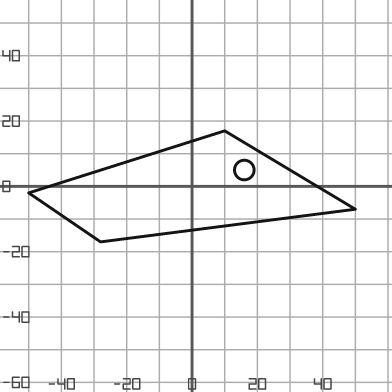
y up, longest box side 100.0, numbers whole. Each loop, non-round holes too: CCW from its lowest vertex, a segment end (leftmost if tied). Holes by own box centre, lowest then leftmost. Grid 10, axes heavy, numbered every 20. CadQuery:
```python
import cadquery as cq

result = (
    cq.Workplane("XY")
    .moveTo(-28.0, -17.0)
    .lineTo(50.0, -7.0)
    .lineTo(10.0, 17.0)
    .lineTo(-50.0, -2.0)
    .close()
    .moveTo(16.0, 5.0)
    .circle(3.0)
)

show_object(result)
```